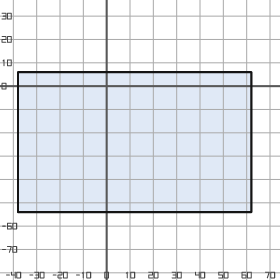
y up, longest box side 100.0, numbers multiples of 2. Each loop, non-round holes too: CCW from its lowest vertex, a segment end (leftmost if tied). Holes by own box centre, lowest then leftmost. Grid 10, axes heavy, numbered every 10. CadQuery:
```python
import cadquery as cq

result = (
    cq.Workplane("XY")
    .moveTo(-38.0, -54.0)
    .lineTo(62.0, -54.0)
    .lineTo(62.0, 6.0)
    .lineTo(-38.0, 6.0)
    .close()
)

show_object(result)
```